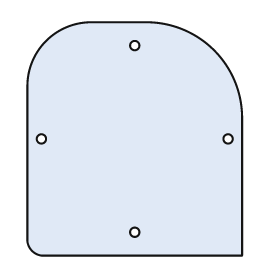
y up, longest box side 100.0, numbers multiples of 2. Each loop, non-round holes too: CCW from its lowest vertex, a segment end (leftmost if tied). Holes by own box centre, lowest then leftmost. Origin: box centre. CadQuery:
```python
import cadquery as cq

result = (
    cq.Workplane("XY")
    .moveTo(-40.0, -50.0)
    .lineTo(46.0, -50.0)
    .lineTo(46.0, 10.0)
    .threePointArc((34.0, 38.0), (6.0, 50.0))
    .lineTo(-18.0, 50.0)
    .threePointArc((-38.0, 42.0), (-46.0, 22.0))
    .lineTo(-46.0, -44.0)
    .threePointArc((-44.0, -48.0), (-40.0, -50.0))
    .close()
    .moveTo(0.0, -40.0)
    .circle(2.0)
    .moveTo(-40.0, 0.0)
    .circle(2.0)
    .moveTo(40.0, 0.0)
    .circle(2.0)
    .moveTo(0.0, 40.0)
    .circle(2.0)
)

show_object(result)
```